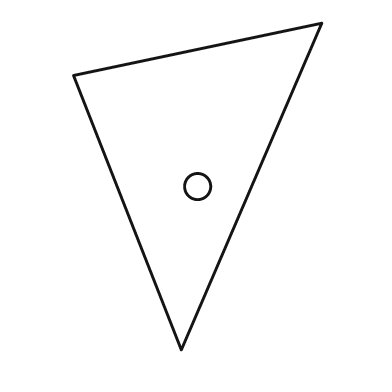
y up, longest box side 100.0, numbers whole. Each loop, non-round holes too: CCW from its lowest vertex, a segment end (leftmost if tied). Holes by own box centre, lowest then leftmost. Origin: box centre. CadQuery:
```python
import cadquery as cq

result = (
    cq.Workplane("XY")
    .moveTo(-5.0, -50.0)
    .lineTo(38.0, 50.0)
    .lineTo(-38.0, 34.0)
    .close()
    .moveTo(0.0, 0.0)
    .circle(4.0)
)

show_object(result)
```